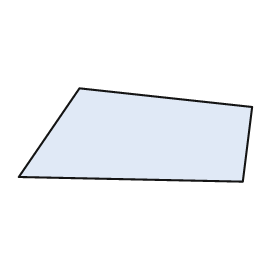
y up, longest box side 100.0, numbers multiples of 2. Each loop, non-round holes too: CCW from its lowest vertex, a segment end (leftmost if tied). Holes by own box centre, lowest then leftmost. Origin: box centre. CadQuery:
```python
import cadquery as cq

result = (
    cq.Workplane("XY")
    .moveTo(46.0, -20.0)
    .lineTo(50.0, 12.0)
    .lineTo(-24.0, 20.0)
    .lineTo(-50.0, -18.0)
    .close()
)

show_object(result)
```